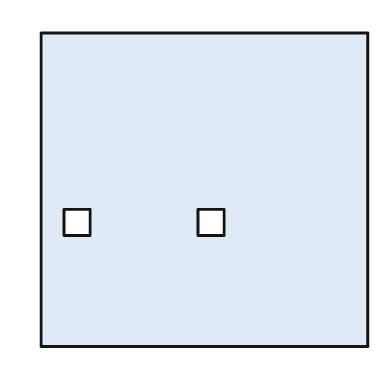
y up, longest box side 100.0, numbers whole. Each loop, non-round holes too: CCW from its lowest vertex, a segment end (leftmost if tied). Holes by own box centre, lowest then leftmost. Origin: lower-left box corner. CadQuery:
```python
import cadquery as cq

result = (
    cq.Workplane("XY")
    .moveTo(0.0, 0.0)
    .lineTo(100.0, 0.0)
    .lineTo(100.0, 96.0)
    .lineTo(0.0, 96.0)
    .close()
    .moveTo(7.0, 34.0)
    .lineTo(15.0, 34.0)
    .lineTo(15.0, 42.0)
    .lineTo(7.0, 42.0)
    .close()
    .moveTo(48.0, 34.0)
    .lineTo(56.0, 34.0)
    .lineTo(56.0, 42.0)
    .lineTo(48.0, 42.0)
    .close()
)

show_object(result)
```